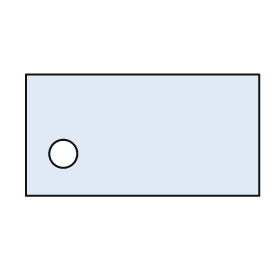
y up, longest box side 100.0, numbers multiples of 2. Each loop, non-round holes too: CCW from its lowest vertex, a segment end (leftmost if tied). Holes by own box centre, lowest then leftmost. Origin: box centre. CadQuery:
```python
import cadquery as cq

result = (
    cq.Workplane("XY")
    .moveTo(-50.0, -26.0)
    .lineTo(50.0, -26.0)
    .lineTo(50.0, 26.0)
    .lineTo(-50.0, 26.0)
    .close()
    .moveTo(-34.0, -8.0)
    .circle(6.0)
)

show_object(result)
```